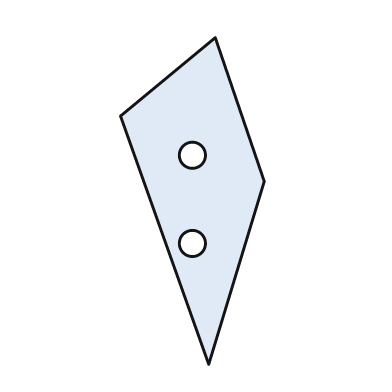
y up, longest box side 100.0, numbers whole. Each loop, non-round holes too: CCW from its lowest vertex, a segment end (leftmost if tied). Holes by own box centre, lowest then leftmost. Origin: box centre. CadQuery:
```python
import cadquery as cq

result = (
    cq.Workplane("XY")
    .moveTo(5.0, -50.0)
    .lineTo(22.0, 6.0)
    .lineTo(7.0, 50.0)
    .lineTo(-22.0, 26.0)
    .close()
    .moveTo(0.0, -13.0)
    .circle(4.0)
    .moveTo(0.0, 14.0)
    .circle(4.0)
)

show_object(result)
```